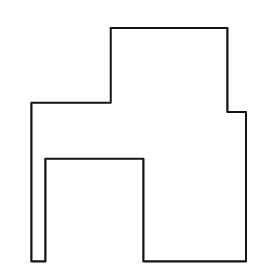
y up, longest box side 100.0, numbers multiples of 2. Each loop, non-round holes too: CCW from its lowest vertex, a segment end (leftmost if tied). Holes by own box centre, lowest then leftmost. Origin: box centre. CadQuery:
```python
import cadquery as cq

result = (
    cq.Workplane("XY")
    .moveTo(-46.0, -50.0)
    .lineTo(-40.0, -50.0)
    .lineTo(-40.0, -6.0)
    .lineTo(2.0, -6.0)
    .lineTo(2.0, -50.0)
    .lineTo(46.0, -50.0)
    .lineTo(46.0, 14.0)
    .lineTo(38.0, 14.0)
    .lineTo(38.0, 50.0)
    .lineTo(-12.0, 50.0)
    .lineTo(-12.0, 18.0)
    .lineTo(-46.0, 18.0)
    .close()
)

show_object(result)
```